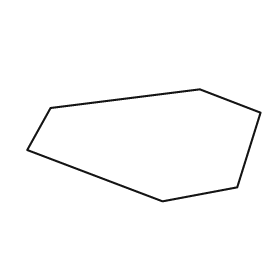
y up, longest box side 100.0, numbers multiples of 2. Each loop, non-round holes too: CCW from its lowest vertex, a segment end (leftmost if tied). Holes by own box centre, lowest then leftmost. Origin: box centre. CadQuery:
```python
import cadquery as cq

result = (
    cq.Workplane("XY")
    .moveTo(8.0, -24.0)
    .lineTo(40.0, -18.0)
    .lineTo(50.0, 14.0)
    .lineTo(24.0, 24.0)
    .lineTo(-40.0, 16.0)
    .lineTo(-50.0, -2.0)
    .close()
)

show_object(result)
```